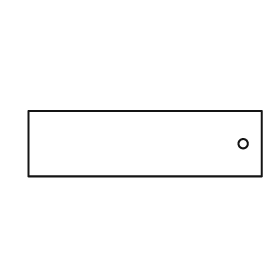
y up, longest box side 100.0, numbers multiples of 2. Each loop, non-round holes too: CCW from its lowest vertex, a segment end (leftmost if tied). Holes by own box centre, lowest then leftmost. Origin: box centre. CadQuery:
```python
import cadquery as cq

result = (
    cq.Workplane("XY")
    .moveTo(-50.0, -14.0)
    .lineTo(50.0, -14.0)
    .lineTo(50.0, 14.0)
    .lineTo(-50.0, 14.0)
    .close()
    .moveTo(42.0, 0.0)
    .circle(2.0)
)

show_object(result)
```